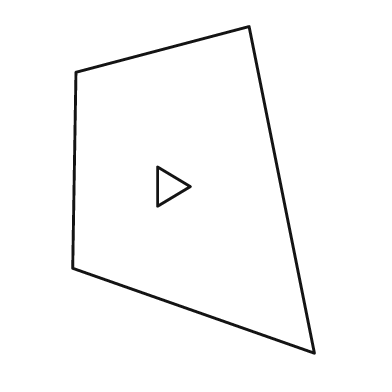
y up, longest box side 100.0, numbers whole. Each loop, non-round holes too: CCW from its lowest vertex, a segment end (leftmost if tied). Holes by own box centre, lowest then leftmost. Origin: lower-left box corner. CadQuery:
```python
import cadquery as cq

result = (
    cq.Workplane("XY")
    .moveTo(74.0, 0.0)
    .lineTo(54.0, 100.0)
    .lineTo(1.0, 86.0)
    .lineTo(0.0, 26.0)
    .close()
    .moveTo(26.0, 45.0)
    .lineTo(36.0, 51.0)
    .lineTo(26.0, 57.0)
    .close()
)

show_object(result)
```